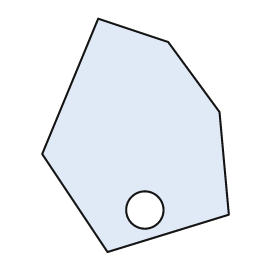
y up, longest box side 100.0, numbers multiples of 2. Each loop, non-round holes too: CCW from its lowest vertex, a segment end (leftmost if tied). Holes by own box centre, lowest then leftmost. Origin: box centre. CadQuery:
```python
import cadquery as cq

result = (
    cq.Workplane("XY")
    .moveTo(-12.0, -50.0)
    .lineTo(40.0, -34.0)
    .lineTo(36.0, 10.0)
    .lineTo(14.0, 40.0)
    .lineTo(-16.0, 50.0)
    .lineTo(-40.0, -8.0)
    .close()
    .moveTo(4.0, -32.0)
    .circle(8.0)
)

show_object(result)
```